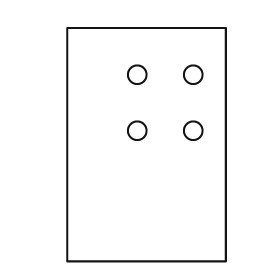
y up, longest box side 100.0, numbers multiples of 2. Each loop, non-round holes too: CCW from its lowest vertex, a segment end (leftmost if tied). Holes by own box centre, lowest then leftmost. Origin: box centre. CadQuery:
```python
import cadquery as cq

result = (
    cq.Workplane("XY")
    .moveTo(-34.0, -50.0)
    .lineTo(34.0, -50.0)
    .lineTo(34.0, 50.0)
    .lineTo(-34.0, 50.0)
    .close()
    .moveTo(-4.0, 6.0)
    .circle(4.0)
    .moveTo(20.0, 6.0)
    .circle(4.0)
    .moveTo(-4.0, 30.0)
    .circle(4.0)
    .moveTo(20.0, 30.0)
    .circle(4.0)
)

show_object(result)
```